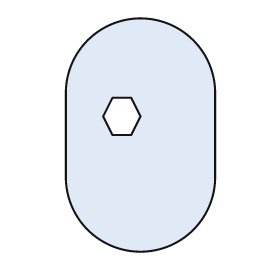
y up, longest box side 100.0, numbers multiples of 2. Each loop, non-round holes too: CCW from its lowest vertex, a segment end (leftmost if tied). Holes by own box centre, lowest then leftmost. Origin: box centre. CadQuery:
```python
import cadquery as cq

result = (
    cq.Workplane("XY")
    .moveTo(-32.0, -18.0)
    .threePointArc((0.0, -50.0), (32.0, -18.0))
    .lineTo(32.0, 18.0)
    .threePointArc((0.0, 50.0), (-32.0, 18.0))
    .close()
    .moveTo(-12.0, 0.0)
    .lineTo(-4.0, 0.0)
    .lineTo(0.0, 8.0)
    .lineTo(-4.0, 16.0)
    .lineTo(-12.0, 16.0)
    .lineTo(-16.0, 8.0)
    .close()
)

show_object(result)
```